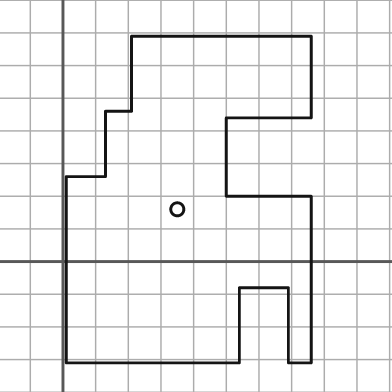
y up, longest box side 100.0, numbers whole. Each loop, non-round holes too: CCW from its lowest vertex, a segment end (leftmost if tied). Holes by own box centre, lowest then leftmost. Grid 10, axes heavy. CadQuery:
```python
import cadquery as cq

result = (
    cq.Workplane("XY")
    .moveTo(1.0, -31.0)
    .lineTo(54.0, -31.0)
    .lineTo(54.0, -8.0)
    .lineTo(69.0, -8.0)
    .lineTo(69.0, -31.0)
    .lineTo(76.0, -31.0)
    .lineTo(76.0, 20.0)
    .lineTo(50.0, 20.0)
    .lineTo(50.0, 44.0)
    .lineTo(76.0, 44.0)
    .lineTo(76.0, 69.0)
    .lineTo(21.0, 69.0)
    .lineTo(21.0, 46.0)
    .lineTo(13.0, 46.0)
    .lineTo(13.0, 26.0)
    .lineTo(1.0, 26.0)
    .close()
    .moveTo(35.0, 16.0)
    .circle(2.0)
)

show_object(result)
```